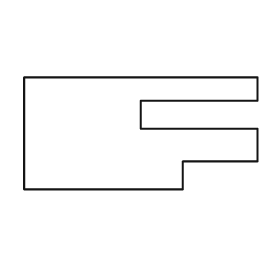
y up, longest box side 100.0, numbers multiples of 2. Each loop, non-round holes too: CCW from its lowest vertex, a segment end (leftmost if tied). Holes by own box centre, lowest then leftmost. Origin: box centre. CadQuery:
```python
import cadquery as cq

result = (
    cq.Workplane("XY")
    .moveTo(-50.0, -24.0)
    .lineTo(18.0, -24.0)
    .lineTo(18.0, -12.0)
    .lineTo(50.0, -12.0)
    .lineTo(50.0, 2.0)
    .lineTo(0.0, 2.0)
    .lineTo(0.0, 14.0)
    .lineTo(50.0, 14.0)
    .lineTo(50.0, 24.0)
    .lineTo(-50.0, 24.0)
    .close()
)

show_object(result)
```